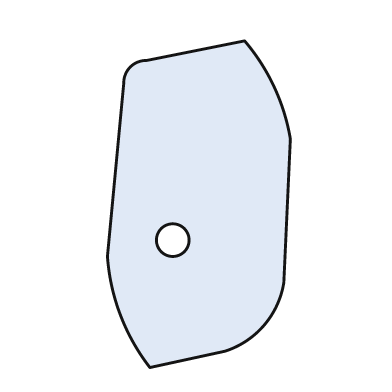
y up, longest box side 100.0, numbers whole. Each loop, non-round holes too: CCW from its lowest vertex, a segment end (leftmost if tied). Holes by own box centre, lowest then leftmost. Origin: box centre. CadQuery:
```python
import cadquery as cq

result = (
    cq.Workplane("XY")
    .moveTo(-15.0, -50.0)
    .lineTo(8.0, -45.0)
    .threePointArc((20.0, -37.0), (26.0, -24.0))
    .lineTo(28.0, 20.0)
    .threePointArc((23.0, 36.0), (14.0, 50.0))
    .lineTo(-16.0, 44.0)
    .threePointArc((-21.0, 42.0), (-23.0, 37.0))
    .lineTo(-28.0, -16.0)
    .threePointArc((-24.0, -34.0), (-15.0, -50.0))
    .close()
    .moveTo(-8.0, -11.0)
    .circle(5.0)
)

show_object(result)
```